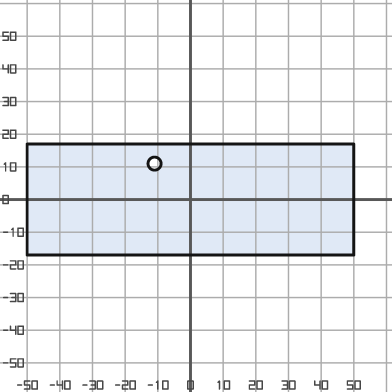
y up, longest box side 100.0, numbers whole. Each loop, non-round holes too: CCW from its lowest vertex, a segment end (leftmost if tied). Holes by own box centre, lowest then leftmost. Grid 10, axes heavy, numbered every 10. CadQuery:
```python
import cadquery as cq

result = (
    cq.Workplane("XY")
    .moveTo(-50.0, -17.0)
    .lineTo(50.0, -17.0)
    .lineTo(50.0, 17.0)
    .lineTo(-50.0, 17.0)
    .close()
    .moveTo(-11.0, 11.0)
    .circle(2.0)
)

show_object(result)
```